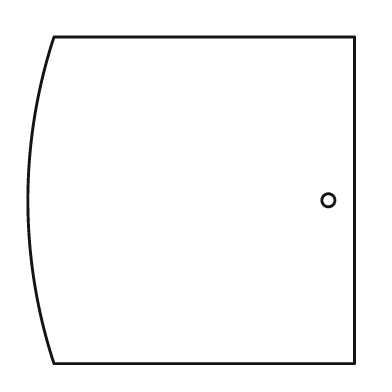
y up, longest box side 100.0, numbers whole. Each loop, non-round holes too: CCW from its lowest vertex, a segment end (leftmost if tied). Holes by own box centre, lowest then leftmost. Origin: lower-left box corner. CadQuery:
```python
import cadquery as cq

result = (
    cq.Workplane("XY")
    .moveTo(8.0, 0.0)
    .lineTo(100.0, 0.0)
    .lineTo(100.0, 100.0)
    .lineTo(8.0, 100.0)
    .threePointArc((0.0, 50.0), (8.0, 0.0))
    .close()
    .moveTo(92.0, 50.0)
    .circle(2.0)
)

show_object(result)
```